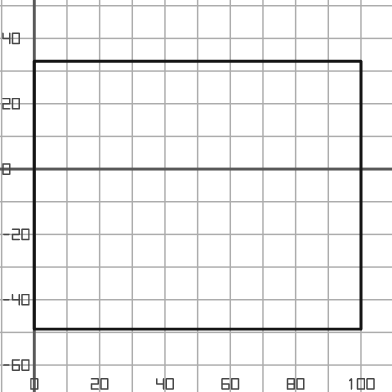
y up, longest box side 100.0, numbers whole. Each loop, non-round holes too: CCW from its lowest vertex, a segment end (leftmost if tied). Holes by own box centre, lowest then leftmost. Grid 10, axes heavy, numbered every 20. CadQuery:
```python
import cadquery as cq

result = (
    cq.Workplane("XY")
    .moveTo(0.0, -49.0)
    .lineTo(100.0, -49.0)
    .lineTo(100.0, 33.0)
    .lineTo(0.0, 33.0)
    .close()
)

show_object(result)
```